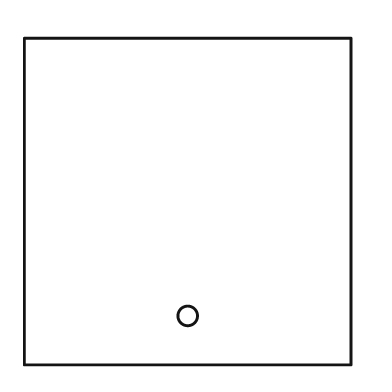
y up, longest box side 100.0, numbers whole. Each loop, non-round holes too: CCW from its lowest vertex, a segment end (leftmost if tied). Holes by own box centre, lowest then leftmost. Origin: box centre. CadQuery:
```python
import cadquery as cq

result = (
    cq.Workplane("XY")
    .moveTo(-50.0, -50.0)
    .lineTo(50.0, -50.0)
    .lineTo(50.0, 50.0)
    .lineTo(-50.0, 50.0)
    .close()
    .moveTo(0.0, -35.0)
    .circle(3.0)
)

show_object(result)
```